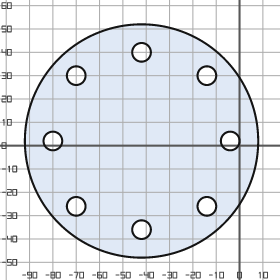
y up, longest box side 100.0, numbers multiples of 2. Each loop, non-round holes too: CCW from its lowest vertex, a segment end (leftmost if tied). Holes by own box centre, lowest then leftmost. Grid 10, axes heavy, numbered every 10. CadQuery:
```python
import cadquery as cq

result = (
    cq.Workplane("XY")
    .moveTo(-42.0, 2.0)
    .circle(50.0)
    .moveTo(-42.0, -36.0)
    .circle(4.0)
    .moveTo(-70.0, -26.0)
    .circle(4.0)
    .moveTo(-14.0, -26.0)
    .circle(4.0)
    .moveTo(-80.0, 2.0)
    .circle(4.0)
    .moveTo(-4.0, 2.0)
    .circle(4.0)
    .moveTo(-70.0, 30.0)
    .circle(4.0)
    .moveTo(-14.0, 30.0)
    .circle(4.0)
    .moveTo(-42.0, 40.0)
    .circle(4.0)
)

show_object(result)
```